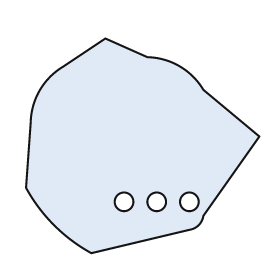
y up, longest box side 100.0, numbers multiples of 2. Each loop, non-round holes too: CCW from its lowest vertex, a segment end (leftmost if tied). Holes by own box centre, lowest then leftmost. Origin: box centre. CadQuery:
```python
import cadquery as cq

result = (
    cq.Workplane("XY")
    .moveTo(-22.0, -46.0)
    .lineTo(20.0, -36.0)
    .threePointArc((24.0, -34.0), (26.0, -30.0))
    .lineTo(50.0, 4.0)
    .lineTo(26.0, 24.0)
    .threePointArc((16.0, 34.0), (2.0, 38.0))
    .lineTo(-16.0, 46.0)
    .lineTo(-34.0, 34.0)
    .threePointArc((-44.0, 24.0), (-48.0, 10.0))
    .lineTo(-50.0, -18.0)
    .threePointArc((-38.0, -34.0), (-22.0, -46.0))
    .close()
    .moveTo(-8.0, -24.0)
    .circle(4.0)
    .moveTo(6.0, -24.0)
    .circle(4.0)
    .moveTo(20.0, -24.0)
    .circle(4.0)
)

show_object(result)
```